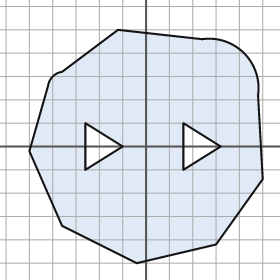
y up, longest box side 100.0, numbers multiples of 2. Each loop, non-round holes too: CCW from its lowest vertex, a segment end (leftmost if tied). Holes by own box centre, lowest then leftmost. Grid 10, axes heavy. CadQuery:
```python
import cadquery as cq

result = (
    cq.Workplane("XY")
    .moveTo(-4.0, -50.0)
    .lineTo(30.0, -42.0)
    .lineTo(50.0, -14.0)
    .lineTo(48.0, 22.0)
    .threePointArc((42.0, 40.0), (24.0, 46.0))
    .lineTo(-12.0, 50.0)
    .lineTo(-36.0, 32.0)
    .threePointArc((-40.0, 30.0), (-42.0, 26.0))
    .lineTo(-50.0, -2.0)
    .lineTo(-36.0, -34.0)
    .close()
    .moveTo(-26.0, -10.0)
    .lineTo(-10.0, 0.0)
    .lineTo(-26.0, 10.0)
    .close()
    .moveTo(16.0, -10.0)
    .lineTo(32.0, 0.0)
    .lineTo(16.0, 10.0)
    .close()
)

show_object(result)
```